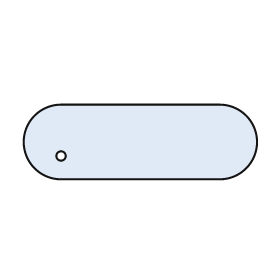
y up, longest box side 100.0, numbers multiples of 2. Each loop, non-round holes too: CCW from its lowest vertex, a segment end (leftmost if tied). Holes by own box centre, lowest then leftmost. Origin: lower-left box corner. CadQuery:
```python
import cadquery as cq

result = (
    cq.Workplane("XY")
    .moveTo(16.0, 0.0)
    .lineTo(84.0, 0.0)
    .threePointArc((100.0, 16.0), (84.0, 32.0))
    .lineTo(16.0, 32.0)
    .threePointArc((0.0, 16.0), (16.0, 0.0))
    .close()
    .moveTo(16.0, 10.0)
    .circle(2.0)
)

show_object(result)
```